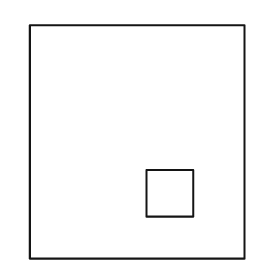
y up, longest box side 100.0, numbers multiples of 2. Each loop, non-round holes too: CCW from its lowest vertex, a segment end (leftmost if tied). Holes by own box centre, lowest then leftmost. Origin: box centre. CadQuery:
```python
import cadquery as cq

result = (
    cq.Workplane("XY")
    .moveTo(-46.0, -50.0)
    .lineTo(46.0, -50.0)
    .lineTo(46.0, 50.0)
    .lineTo(-46.0, 50.0)
    .close()
    .moveTo(4.0, -32.0)
    .lineTo(24.0, -32.0)
    .lineTo(24.0, -12.0)
    .lineTo(4.0, -12.0)
    .close()
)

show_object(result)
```